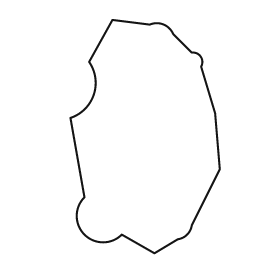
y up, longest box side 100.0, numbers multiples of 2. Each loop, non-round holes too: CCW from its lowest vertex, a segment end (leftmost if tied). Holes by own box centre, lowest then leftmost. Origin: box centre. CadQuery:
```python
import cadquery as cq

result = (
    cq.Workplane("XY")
    .moveTo(4.0, -50.0)
    .lineTo(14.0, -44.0)
    .threePointArc((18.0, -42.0), (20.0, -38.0))
    .lineTo(32.0, -14.0)
    .lineTo(30.0, 10.0)
    .lineTo(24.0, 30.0)
    .threePointArc((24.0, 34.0), (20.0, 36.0))
    .lineTo(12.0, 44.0)
    .threePointArc((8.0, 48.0), (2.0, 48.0))
    .lineTo(-14.0, 50.0)
    .lineTo(-24.0, 32.0)
    .threePointArc((-22.0, 18.0), (-32.0, 8.0))
    .lineTo(-26.0, -26.0)
    .threePointArc((-26.0, -42.0), (-10.0, -42.0))
    .close()
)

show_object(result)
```